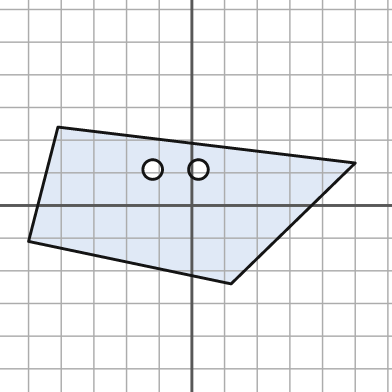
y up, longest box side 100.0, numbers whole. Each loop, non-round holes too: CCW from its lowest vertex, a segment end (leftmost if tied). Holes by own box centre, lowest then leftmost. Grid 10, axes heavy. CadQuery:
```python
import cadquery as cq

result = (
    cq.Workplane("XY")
    .moveTo(12.0, -24.0)
    .lineTo(50.0, 13.0)
    .lineTo(-41.0, 24.0)
    .lineTo(-50.0, -11.0)
    .close()
    .moveTo(-12.0, 11.0)
    .circle(3.0)
    .moveTo(2.0, 11.0)
    .circle(3.0)
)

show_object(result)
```